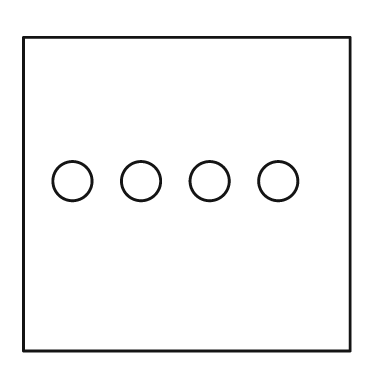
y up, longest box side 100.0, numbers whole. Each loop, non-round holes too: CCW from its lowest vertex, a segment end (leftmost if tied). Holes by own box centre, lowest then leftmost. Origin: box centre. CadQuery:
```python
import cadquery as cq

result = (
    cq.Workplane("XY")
    .moveTo(-50.0, -48.0)
    .lineTo(50.0, -48.0)
    .lineTo(50.0, 48.0)
    .lineTo(-50.0, 48.0)
    .close()
    .moveTo(-35.0, 4.0)
    .circle(6.0)
    .moveTo(-14.0, 4.0)
    .circle(6.0)
    .moveTo(7.0, 4.0)
    .circle(6.0)
    .moveTo(28.0, 4.0)
    .circle(6.0)
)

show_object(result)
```